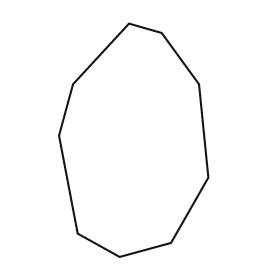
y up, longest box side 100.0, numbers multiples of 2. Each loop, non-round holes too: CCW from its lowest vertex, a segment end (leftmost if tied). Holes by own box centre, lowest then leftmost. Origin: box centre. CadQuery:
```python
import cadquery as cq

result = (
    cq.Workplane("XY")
    .moveTo(-6.0, -50.0)
    .lineTo(16.0, -44.0)
    .lineTo(32.0, -16.0)
    .lineTo(28.0, 24.0)
    .lineTo(12.0, 46.0)
    .lineTo(-2.0, 50.0)
    .lineTo(-26.0, 24.0)
    .lineTo(-32.0, 2.0)
    .lineTo(-24.0, -40.0)
    .close()
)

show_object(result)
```